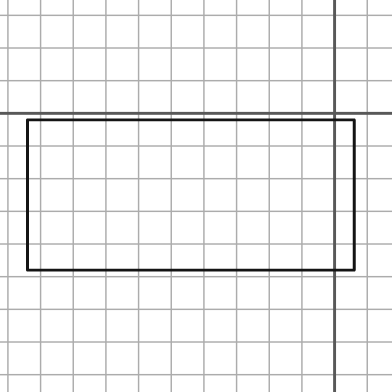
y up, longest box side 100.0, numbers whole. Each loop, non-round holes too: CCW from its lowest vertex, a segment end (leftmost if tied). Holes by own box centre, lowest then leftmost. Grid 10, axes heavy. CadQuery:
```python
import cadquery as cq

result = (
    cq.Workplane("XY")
    .moveTo(-94.0, -48.0)
    .lineTo(6.0, -48.0)
    .lineTo(6.0, -2.0)
    .lineTo(-94.0, -2.0)
    .close()
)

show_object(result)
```